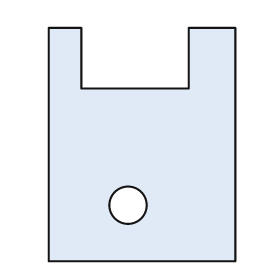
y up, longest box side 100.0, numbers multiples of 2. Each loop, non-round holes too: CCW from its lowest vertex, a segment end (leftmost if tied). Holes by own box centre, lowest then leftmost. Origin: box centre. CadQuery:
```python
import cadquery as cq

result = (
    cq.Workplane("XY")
    .moveTo(-40.0, -50.0)
    .lineTo(40.0, -50.0)
    .lineTo(40.0, 50.0)
    .lineTo(20.0, 50.0)
    .lineTo(20.0, 24.0)
    .lineTo(-26.0, 24.0)
    .lineTo(-26.0, 50.0)
    .lineTo(-40.0, 50.0)
    .close()
    .moveTo(-6.0, -26.0)
    .circle(8.0)
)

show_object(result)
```